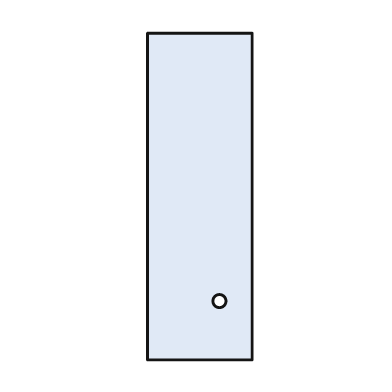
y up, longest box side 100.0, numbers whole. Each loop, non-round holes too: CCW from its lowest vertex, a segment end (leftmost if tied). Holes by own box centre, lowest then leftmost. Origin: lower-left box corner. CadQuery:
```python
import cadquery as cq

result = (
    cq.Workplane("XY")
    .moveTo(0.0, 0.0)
    .lineTo(32.0, 0.0)
    .lineTo(32.0, 100.0)
    .lineTo(0.0, 100.0)
    .close()
    .moveTo(22.0, 18.0)
    .circle(2.0)
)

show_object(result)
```